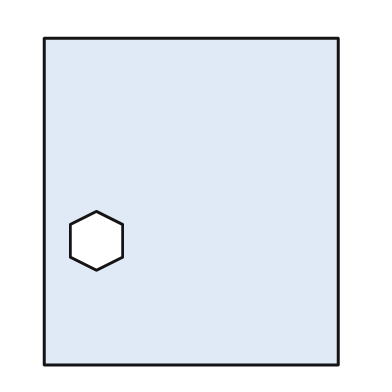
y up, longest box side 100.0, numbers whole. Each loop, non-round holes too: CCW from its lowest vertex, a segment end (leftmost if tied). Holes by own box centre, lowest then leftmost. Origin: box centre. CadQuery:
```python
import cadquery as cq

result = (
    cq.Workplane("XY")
    .moveTo(-45.0, -50.0)
    .lineTo(45.0, -50.0)
    .lineTo(45.0, 50.0)
    .lineTo(-45.0, 50.0)
    .close()
    .moveTo(-29.0, -21.0)
    .lineTo(-21.0, -17.0)
    .lineTo(-21.0, -7.0)
    .lineTo(-29.0, -3.0)
    .lineTo(-37.0, -7.0)
    .lineTo(-37.0, -17.0)
    .close()
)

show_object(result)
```